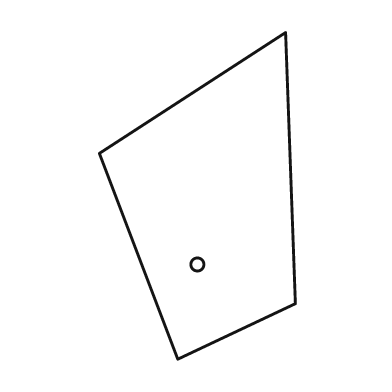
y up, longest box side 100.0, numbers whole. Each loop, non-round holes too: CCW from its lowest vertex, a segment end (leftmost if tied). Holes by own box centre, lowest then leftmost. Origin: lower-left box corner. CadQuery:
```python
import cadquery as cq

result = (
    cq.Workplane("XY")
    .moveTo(24.0, 0.0)
    .lineTo(60.0, 17.0)
    .lineTo(57.0, 100.0)
    .lineTo(0.0, 63.0)
    .close()
    .moveTo(30.0, 29.0)
    .circle(2.0)
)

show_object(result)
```